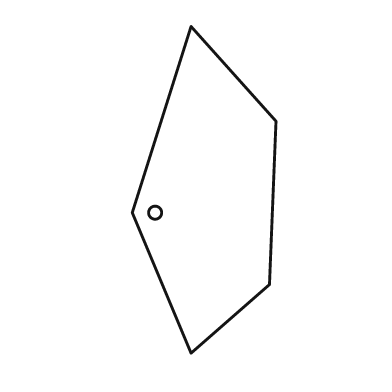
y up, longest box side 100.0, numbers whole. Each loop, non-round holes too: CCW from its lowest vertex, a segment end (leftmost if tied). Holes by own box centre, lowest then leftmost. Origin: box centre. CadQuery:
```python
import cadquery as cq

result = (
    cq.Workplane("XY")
    .moveTo(-4.0, -50.0)
    .lineTo(20.0, -29.0)
    .lineTo(22.0, 21.0)
    .lineTo(-4.0, 50.0)
    .lineTo(-22.0, -7.0)
    .close()
    .moveTo(-15.0, -7.0)
    .circle(2.0)
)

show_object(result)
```